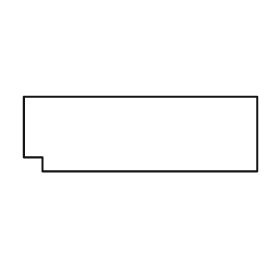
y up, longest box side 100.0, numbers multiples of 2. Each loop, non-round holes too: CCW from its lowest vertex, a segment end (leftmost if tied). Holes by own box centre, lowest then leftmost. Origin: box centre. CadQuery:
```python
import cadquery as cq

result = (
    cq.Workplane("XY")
    .moveTo(-42.0, -16.0)
    .lineTo(50.0, -16.0)
    .lineTo(50.0, 16.0)
    .lineTo(-50.0, 16.0)
    .lineTo(-50.0, -10.0)
    .lineTo(-42.0, -10.0)
    .close()
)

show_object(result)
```